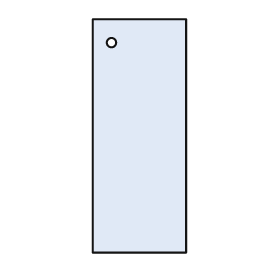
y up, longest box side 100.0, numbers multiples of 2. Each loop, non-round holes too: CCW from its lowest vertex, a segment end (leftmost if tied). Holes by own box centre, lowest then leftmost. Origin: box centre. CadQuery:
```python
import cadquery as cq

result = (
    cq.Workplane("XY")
    .moveTo(-20.0, -50.0)
    .lineTo(20.0, -50.0)
    .lineTo(20.0, 50.0)
    .lineTo(-20.0, 50.0)
    .close()
    .moveTo(-12.0, 40.0)
    .circle(2.0)
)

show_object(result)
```